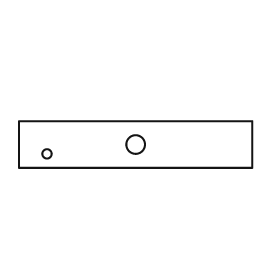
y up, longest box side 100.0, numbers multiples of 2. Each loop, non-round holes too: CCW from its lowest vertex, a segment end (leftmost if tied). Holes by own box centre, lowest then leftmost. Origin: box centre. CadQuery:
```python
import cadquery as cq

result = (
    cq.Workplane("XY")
    .moveTo(-50.0, -10.0)
    .lineTo(50.0, -10.0)
    .lineTo(50.0, 10.0)
    .lineTo(-50.0, 10.0)
    .close()
    .moveTo(-38.0, -4.0)
    .circle(2.0)
    .moveTo(0.0, 0.0)
    .circle(4.0)
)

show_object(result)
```